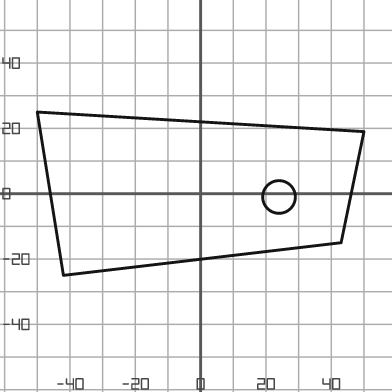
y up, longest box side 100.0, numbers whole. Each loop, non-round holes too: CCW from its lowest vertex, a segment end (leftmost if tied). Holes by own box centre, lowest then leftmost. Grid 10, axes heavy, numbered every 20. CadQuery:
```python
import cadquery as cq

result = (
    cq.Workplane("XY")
    .moveTo(-42.0, -25.0)
    .lineTo(43.0, -15.0)
    .lineTo(50.0, 19.0)
    .lineTo(-50.0, 25.0)
    .close()
    .moveTo(24.0, -1.0)
    .circle(5.0)
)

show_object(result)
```